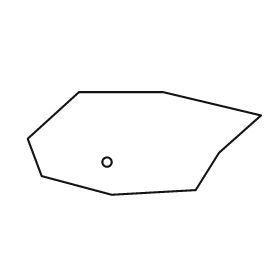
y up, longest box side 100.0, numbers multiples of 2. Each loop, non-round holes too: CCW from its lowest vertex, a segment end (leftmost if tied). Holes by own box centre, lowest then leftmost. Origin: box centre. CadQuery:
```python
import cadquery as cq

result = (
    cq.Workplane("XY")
    .moveTo(-14.0, -22.0)
    .lineTo(22.0, -20.0)
    .lineTo(32.0, -4.0)
    .lineTo(50.0, 12.0)
    .lineTo(8.0, 22.0)
    .lineTo(-28.0, 22.0)
    .lineTo(-50.0, 2.0)
    .lineTo(-44.0, -14.0)
    .close()
    .moveTo(-16.0, -8.0)
    .circle(2.0)
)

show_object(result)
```